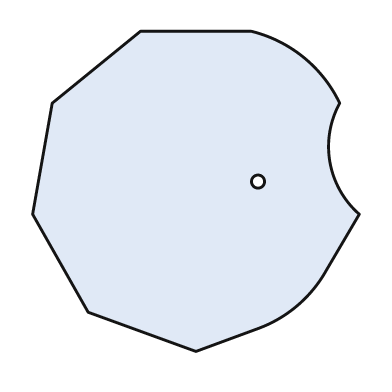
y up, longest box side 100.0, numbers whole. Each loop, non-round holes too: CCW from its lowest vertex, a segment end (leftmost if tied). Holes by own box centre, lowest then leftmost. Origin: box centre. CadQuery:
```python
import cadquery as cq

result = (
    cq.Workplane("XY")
    .moveTo(0.0, -49.0)
    .lineTo(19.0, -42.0)
    .threePointArc((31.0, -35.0), (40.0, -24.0))
    .lineTo(50.0, -7.0)
    .threePointArc((41.0, 9.0), (44.0, 27.0))
    .threePointArc((33.0, 41.0), (17.0, 49.0))
    .lineTo(-17.0, 49.0)
    .lineTo(-44.0, 27.0)
    .lineTo(-50.0, -7.0)
    .lineTo(-33.0, -37.0)
    .close()
    .moveTo(19.0, 3.0)
    .circle(2.0)
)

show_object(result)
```